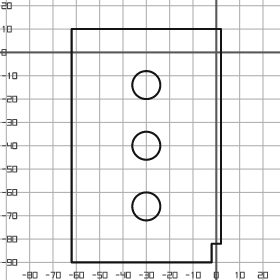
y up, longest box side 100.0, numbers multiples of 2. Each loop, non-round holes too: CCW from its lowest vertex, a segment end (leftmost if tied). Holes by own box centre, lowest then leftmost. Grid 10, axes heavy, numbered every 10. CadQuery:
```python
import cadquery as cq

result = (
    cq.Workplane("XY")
    .moveTo(-62.0, -90.0)
    .lineTo(-2.0, -90.0)
    .lineTo(-2.0, -82.0)
    .lineTo(2.0, -82.0)
    .lineTo(2.0, 10.0)
    .lineTo(-62.0, 10.0)
    .close()
    .moveTo(-30.0, -66.0)
    .circle(6.0)
    .moveTo(-30.0, -40.0)
    .circle(6.0)
    .moveTo(-30.0, -14.0)
    .circle(6.0)
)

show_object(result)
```